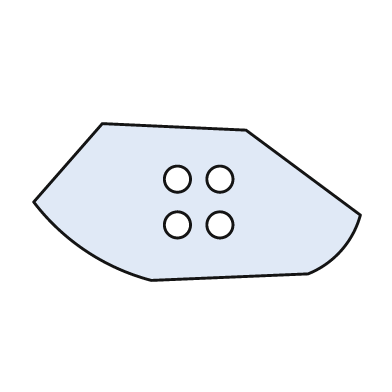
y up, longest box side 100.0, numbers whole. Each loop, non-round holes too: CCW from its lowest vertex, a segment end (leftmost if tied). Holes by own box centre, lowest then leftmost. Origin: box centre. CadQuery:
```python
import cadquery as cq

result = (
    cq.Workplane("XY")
    .moveTo(-14.0, -24.0)
    .lineTo(34.0, -22.0)
    .threePointArc((44.0, -15.0), (50.0, -4.0))
    .lineTo(15.0, 22.0)
    .lineTo(-29.0, 24.0)
    .lineTo(-50.0, 0.0)
    .threePointArc((-34.0, -15.0), (-14.0, -24.0))
    .close()
    .moveTo(-6.0, -7.0)
    .circle(4.0)
    .moveTo(7.0, -7.0)
    .circle(4.0)
    .moveTo(-6.0, 7.0)
    .circle(4.0)
    .moveTo(7.0, 7.0)
    .circle(4.0)
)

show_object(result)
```